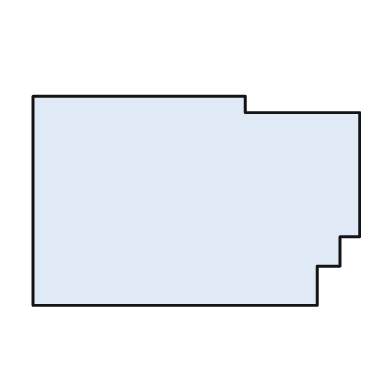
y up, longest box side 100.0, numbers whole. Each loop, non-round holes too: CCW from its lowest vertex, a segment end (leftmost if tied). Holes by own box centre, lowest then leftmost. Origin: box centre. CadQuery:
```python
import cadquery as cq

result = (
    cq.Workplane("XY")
    .moveTo(-50.0, -32.0)
    .lineTo(37.0, -32.0)
    .lineTo(37.0, -20.0)
    .lineTo(44.0, -20.0)
    .lineTo(44.0, -11.0)
    .lineTo(50.0, -11.0)
    .lineTo(50.0, 27.0)
    .lineTo(15.0, 27.0)
    .lineTo(15.0, 32.0)
    .lineTo(-50.0, 32.0)
    .close()
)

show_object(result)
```